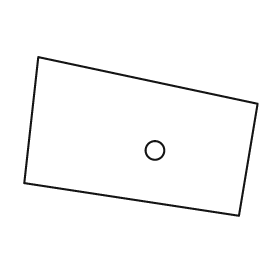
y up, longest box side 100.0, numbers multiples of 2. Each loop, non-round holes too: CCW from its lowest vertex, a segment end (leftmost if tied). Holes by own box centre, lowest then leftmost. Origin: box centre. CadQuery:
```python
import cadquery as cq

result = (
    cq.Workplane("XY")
    .moveTo(42.0, -34.0)
    .lineTo(50.0, 14.0)
    .lineTo(-44.0, 34.0)
    .lineTo(-50.0, -20.0)
    .close()
    .moveTo(6.0, -6.0)
    .circle(4.0)
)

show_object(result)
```